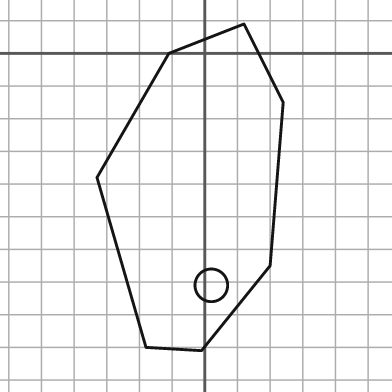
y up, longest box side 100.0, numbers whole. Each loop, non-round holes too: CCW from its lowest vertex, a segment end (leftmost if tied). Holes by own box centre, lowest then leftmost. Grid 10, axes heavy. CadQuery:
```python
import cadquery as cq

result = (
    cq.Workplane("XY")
    .moveTo(-1.0, -91.0)
    .lineTo(20.0, -65.0)
    .lineTo(24.0, -15.0)
    .lineTo(12.0, 9.0)
    .lineTo(-11.0, 0.0)
    .lineTo(-33.0, -38.0)
    .lineTo(-18.0, -90.0)
    .close()
    .moveTo(2.0, -71.0)
    .circle(5.0)
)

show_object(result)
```